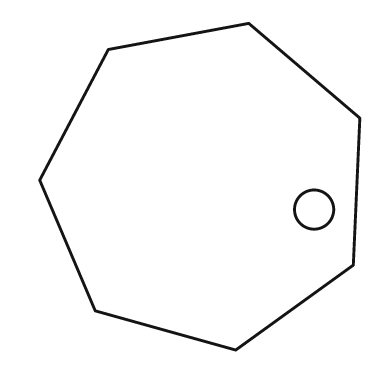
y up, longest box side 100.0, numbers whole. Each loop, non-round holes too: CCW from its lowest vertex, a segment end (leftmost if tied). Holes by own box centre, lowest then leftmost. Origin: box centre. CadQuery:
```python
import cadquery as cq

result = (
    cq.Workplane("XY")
    .moveTo(11.0, -50.0)
    .lineTo(47.0, -24.0)
    .lineTo(49.0, 21.0)
    .lineTo(15.0, 50.0)
    .lineTo(-28.0, 42.0)
    .lineTo(-49.0, 2.0)
    .lineTo(-32.0, -38.0)
    .close()
    .moveTo(35.0, -7.0)
    .circle(6.0)
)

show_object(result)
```